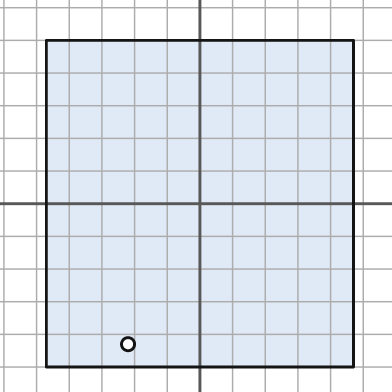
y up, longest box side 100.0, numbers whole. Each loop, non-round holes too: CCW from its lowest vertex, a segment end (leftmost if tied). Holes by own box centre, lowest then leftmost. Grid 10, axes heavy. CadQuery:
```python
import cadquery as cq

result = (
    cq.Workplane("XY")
    .moveTo(-47.0, -50.0)
    .lineTo(47.0, -50.0)
    .lineTo(47.0, 50.0)
    .lineTo(-47.0, 50.0)
    .close()
    .moveTo(-22.0, -43.0)
    .circle(2.0)
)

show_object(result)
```